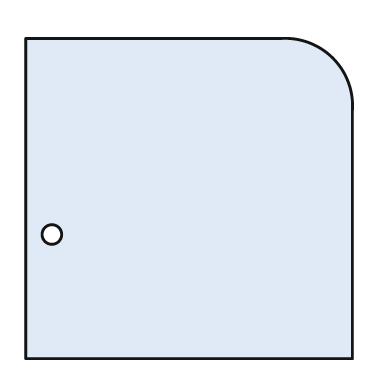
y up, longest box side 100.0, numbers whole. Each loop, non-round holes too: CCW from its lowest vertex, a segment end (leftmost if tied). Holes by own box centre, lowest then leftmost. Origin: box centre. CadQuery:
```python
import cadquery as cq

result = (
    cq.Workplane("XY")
    .moveTo(-50.0, -49.0)
    .lineTo(50.0, -49.0)
    .lineTo(50.0, 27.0)
    .threePointArc((44.0, 43.0), (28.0, 49.0))
    .lineTo(-50.0, 49.0)
    .close()
    .moveTo(-42.0, -11.0)
    .circle(3.0)
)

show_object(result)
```